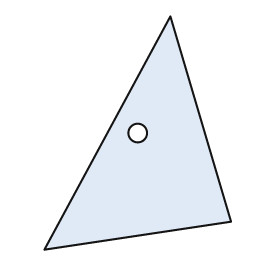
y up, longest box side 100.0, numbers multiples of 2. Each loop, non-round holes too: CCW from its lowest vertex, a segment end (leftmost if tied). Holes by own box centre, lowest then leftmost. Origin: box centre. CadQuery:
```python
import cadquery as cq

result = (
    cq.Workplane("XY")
    .moveTo(-40.0, -50.0)
    .lineTo(40.0, -38.0)
    .lineTo(14.0, 50.0)
    .close()
    .moveTo(0.0, 0.0)
    .circle(4.0)
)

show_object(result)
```